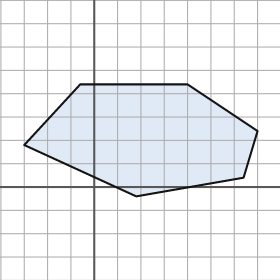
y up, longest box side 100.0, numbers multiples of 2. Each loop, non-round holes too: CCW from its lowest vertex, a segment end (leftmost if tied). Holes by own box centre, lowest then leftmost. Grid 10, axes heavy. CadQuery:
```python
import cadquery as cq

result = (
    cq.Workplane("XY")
    .moveTo(18.0, -4.0)
    .lineTo(64.0, 4.0)
    .lineTo(70.0, 24.0)
    .lineTo(40.0, 44.0)
    .lineTo(-6.0, 44.0)
    .lineTo(-30.0, 18.0)
    .close()
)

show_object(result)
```